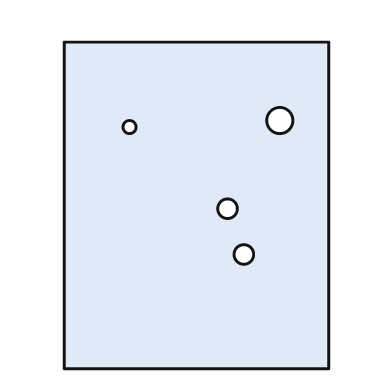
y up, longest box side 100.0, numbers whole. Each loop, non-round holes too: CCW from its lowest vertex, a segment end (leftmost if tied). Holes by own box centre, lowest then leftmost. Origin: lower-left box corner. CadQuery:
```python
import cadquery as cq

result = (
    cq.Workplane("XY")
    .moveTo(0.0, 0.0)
    .lineTo(81.0, 0.0)
    .lineTo(81.0, 100.0)
    .lineTo(0.0, 100.0)
    .close()
    .moveTo(55.0, 35.0)
    .circle(3.0)
    .moveTo(50.0, 49.0)
    .circle(3.0)
    .moveTo(20.0, 74.0)
    .circle(2.0)
    .moveTo(66.0, 76.0)
    .circle(4.0)
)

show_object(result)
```